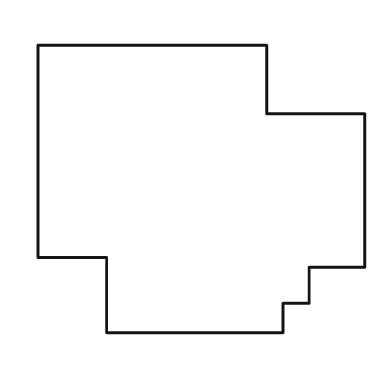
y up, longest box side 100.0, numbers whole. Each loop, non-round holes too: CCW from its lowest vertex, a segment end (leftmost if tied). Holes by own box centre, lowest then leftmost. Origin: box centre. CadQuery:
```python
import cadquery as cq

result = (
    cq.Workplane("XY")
    .moveTo(-29.0, -44.0)
    .lineTo(25.0, -44.0)
    .lineTo(25.0, -35.0)
    .lineTo(33.0, -35.0)
    .lineTo(33.0, -24.0)
    .lineTo(50.0, -24.0)
    .lineTo(50.0, 23.0)
    .lineTo(20.0, 23.0)
    .lineTo(20.0, 44.0)
    .lineTo(-50.0, 44.0)
    .lineTo(-50.0, -21.0)
    .lineTo(-29.0, -21.0)
    .close()
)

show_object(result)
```